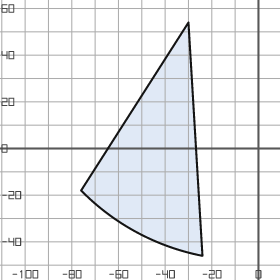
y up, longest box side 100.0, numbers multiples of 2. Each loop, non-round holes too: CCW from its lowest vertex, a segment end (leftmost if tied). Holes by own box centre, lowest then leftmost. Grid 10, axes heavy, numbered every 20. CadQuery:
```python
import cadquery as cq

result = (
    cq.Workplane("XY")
    .moveTo(-24.0, -46.0)
    .lineTo(-30.0, 54.0)
    .lineTo(-76.0, -18.0)
    .threePointArc((-52.0, -36.0), (-24.0, -46.0))
    .close()
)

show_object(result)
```